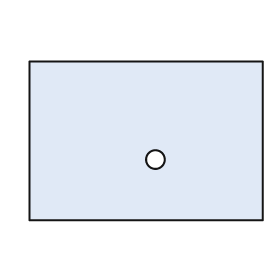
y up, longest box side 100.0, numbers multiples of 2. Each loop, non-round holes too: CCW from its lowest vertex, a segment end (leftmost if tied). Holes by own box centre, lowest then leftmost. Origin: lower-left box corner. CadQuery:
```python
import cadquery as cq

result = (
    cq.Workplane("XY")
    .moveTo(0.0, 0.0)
    .lineTo(100.0, 0.0)
    .lineTo(100.0, 68.0)
    .lineTo(0.0, 68.0)
    .close()
    .moveTo(54.0, 26.0)
    .circle(4.0)
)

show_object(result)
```